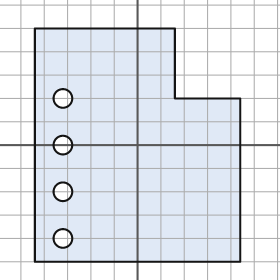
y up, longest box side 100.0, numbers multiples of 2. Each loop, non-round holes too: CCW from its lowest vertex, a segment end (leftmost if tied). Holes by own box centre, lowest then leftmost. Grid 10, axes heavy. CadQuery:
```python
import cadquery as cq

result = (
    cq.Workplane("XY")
    .moveTo(-44.0, -50.0)
    .lineTo(44.0, -50.0)
    .lineTo(44.0, 20.0)
    .lineTo(16.0, 20.0)
    .lineTo(16.0, 50.0)
    .lineTo(-44.0, 50.0)
    .close()
    .moveTo(-32.0, -40.0)
    .circle(4.0)
    .moveTo(-32.0, -20.0)
    .circle(4.0)
    .moveTo(-32.0, 0.0)
    .circle(4.0)
    .moveTo(-32.0, 20.0)
    .circle(4.0)
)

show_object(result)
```